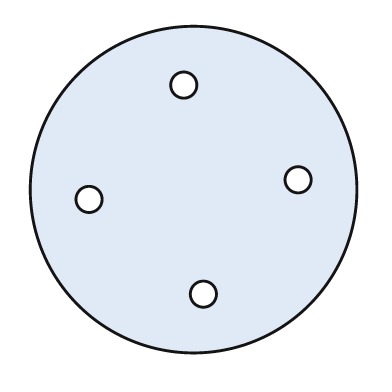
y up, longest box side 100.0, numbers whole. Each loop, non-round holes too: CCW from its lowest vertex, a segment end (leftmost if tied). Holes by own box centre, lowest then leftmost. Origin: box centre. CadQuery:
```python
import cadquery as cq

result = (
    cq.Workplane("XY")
    .moveTo(0.0, 0.0)
    .circle(50.0)
    .moveTo(3.0, -32.0)
    .circle(4.0)
    .moveTo(-32.0, -3.0)
    .circle(4.0)
    .moveTo(32.0, 3.0)
    .circle(4.0)
    .moveTo(-3.0, 32.0)
    .circle(4.0)
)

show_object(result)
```